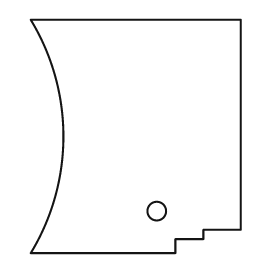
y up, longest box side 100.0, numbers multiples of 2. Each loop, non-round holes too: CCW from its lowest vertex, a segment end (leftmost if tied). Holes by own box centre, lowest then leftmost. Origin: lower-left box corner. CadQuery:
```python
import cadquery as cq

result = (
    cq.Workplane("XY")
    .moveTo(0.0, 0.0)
    .lineTo(62.0, 0.0)
    .lineTo(62.0, 6.0)
    .lineTo(74.0, 6.0)
    .lineTo(74.0, 10.0)
    .lineTo(90.0, 10.0)
    .lineTo(90.0, 100.0)
    .lineTo(0.0, 100.0)
    .threePointArc((14.0, 50.0), (0.0, 0.0))
    .close()
    .moveTo(54.0, 18.0)
    .circle(4.0)
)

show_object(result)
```